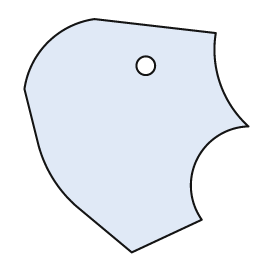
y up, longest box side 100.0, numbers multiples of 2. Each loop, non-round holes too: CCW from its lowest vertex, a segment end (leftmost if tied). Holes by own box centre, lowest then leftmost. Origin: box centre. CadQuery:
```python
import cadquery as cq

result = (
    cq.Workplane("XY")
    .moveTo(-2.0, -50.0)
    .lineTo(28.0, -36.0)
    .threePointArc((26.0, -10.0), (48.0, 4.0))
    .threePointArc((36.0, 22.0), (34.0, 44.0))
    .lineTo(-18.0, 50.0)
    .threePointArc((-38.0, 40.0), (-48.0, 20.0))
    .lineTo(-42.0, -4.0)
    .threePointArc((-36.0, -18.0), (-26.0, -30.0))
    .close()
    .moveTo(4.0, 30.0)
    .circle(4.0)
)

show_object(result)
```